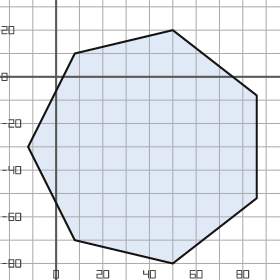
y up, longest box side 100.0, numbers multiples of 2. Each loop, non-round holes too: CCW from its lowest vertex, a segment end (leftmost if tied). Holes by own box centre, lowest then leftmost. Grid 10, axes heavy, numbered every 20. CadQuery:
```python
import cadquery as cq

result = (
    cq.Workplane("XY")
    .moveTo(50.0, -80.0)
    .lineTo(86.0, -52.0)
    .lineTo(86.0, -8.0)
    .lineTo(50.0, 20.0)
    .lineTo(8.0, 10.0)
    .lineTo(-12.0, -30.0)
    .lineTo(8.0, -70.0)
    .close()
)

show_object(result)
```